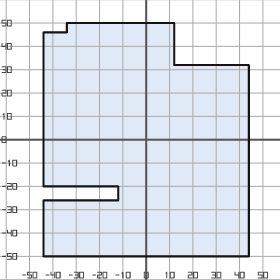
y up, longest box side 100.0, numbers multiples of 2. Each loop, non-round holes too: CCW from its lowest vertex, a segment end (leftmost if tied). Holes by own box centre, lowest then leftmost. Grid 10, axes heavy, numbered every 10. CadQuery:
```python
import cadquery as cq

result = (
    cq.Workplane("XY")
    .moveTo(-44.0, -50.0)
    .lineTo(44.0, -50.0)
    .lineTo(44.0, 32.0)
    .lineTo(12.0, 32.0)
    .lineTo(12.0, 50.0)
    .lineTo(-34.0, 50.0)
    .lineTo(-34.0, 46.0)
    .lineTo(-44.0, 46.0)
    .lineTo(-44.0, -20.0)
    .lineTo(-12.0, -20.0)
    .lineTo(-12.0, -26.0)
    .lineTo(-44.0, -26.0)
    .close()
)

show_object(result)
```